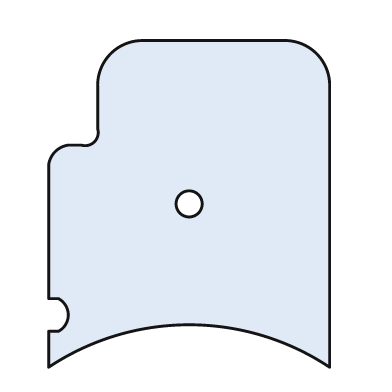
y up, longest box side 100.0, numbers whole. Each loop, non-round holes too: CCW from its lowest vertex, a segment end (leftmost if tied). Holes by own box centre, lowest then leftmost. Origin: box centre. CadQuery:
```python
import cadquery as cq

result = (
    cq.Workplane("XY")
    .moveTo(-43.0, -50.0)
    .threePointArc((0.0, -37.0), (43.0, -50.0))
    .lineTo(43.0, 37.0)
    .threePointArc((39.0, 46.0), (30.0, 50.0))
    .lineTo(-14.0, 50.0)
    .threePointArc((-24.0, 46.0), (-28.0, 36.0))
    .lineTo(-28.0, 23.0)
    .threePointArc((-29.0, 19.0), (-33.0, 18.0))
    .lineTo(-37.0, 18.0)
    .threePointArc((-41.0, 16.0), (-43.0, 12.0))
    .lineTo(-43.0, -29.0)
    .lineTo(-40.0, -29.0)
    .threePointArc((-37.0, -34.0), (-40.0, -39.0))
    .lineTo(-43.0, -39.0)
    .close()
    .moveTo(0.0, 0.0)
    .circle(4.0)
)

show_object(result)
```